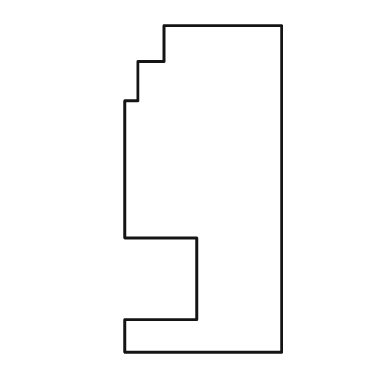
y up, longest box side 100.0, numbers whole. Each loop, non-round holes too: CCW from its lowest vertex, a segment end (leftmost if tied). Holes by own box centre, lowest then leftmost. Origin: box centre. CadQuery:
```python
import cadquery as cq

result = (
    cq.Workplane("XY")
    .moveTo(-24.0, -50.0)
    .lineTo(24.0, -50.0)
    .lineTo(24.0, 50.0)
    .lineTo(-12.0, 50.0)
    .lineTo(-12.0, 39.0)
    .lineTo(-20.0, 39.0)
    .lineTo(-20.0, 27.0)
    .lineTo(-24.0, 27.0)
    .lineTo(-24.0, -15.0)
    .lineTo(-2.0, -15.0)
    .lineTo(-2.0, -40.0)
    .lineTo(-24.0, -40.0)
    .close()
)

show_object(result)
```